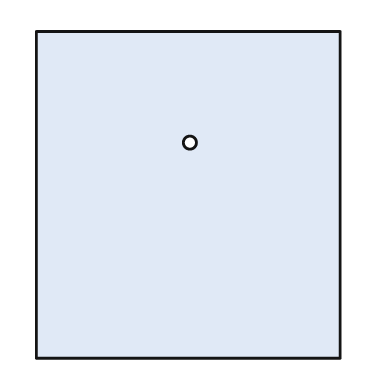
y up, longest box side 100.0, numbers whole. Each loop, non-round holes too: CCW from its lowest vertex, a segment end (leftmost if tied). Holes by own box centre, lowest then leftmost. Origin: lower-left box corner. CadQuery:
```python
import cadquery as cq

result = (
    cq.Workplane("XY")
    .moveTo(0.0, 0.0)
    .lineTo(93.0, 0.0)
    .lineTo(93.0, 100.0)
    .lineTo(0.0, 100.0)
    .close()
    .moveTo(47.0, 66.0)
    .circle(2.0)
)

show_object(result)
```